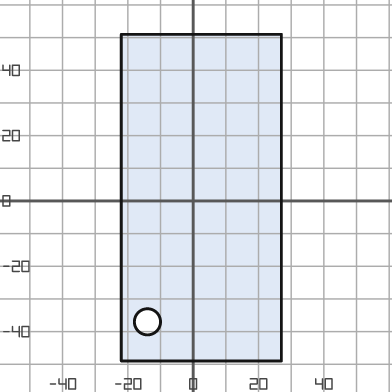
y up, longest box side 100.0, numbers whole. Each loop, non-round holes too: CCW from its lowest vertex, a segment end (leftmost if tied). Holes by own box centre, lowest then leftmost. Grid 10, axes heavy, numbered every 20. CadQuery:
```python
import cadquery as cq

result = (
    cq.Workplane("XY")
    .moveTo(-22.0, -49.0)
    .lineTo(27.0, -49.0)
    .lineTo(27.0, 51.0)
    .lineTo(-22.0, 51.0)
    .close()
    .moveTo(-14.0, -37.0)
    .circle(4.0)
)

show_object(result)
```